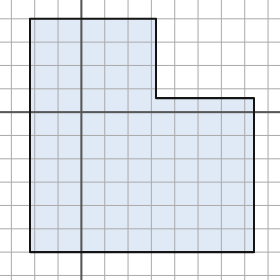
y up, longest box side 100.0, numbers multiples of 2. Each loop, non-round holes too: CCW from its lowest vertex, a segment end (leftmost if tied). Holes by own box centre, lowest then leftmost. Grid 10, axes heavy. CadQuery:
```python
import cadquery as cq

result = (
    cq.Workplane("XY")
    .moveTo(-22.0, -60.0)
    .lineTo(74.0, -60.0)
    .lineTo(74.0, 6.0)
    .lineTo(32.0, 6.0)
    .lineTo(32.0, 40.0)
    .lineTo(-22.0, 40.0)
    .close()
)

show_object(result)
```